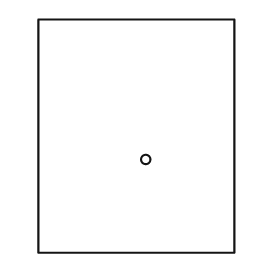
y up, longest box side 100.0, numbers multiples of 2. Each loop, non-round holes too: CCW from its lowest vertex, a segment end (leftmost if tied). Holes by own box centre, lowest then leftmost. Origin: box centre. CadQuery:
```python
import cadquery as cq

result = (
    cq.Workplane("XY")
    .moveTo(-42.0, -50.0)
    .lineTo(42.0, -50.0)
    .lineTo(42.0, 50.0)
    .lineTo(-42.0, 50.0)
    .close()
    .moveTo(4.0, -10.0)
    .circle(2.0)
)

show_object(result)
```